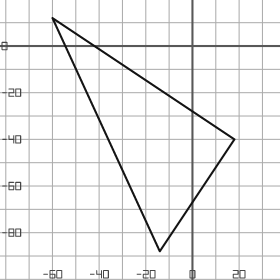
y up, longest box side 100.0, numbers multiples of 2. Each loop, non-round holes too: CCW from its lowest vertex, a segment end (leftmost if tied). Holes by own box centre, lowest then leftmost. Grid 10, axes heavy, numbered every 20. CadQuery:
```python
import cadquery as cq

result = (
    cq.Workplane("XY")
    .moveTo(-14.0, -88.0)
    .lineTo(18.0, -40.0)
    .lineTo(-60.0, 12.0)
    .close()
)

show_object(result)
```